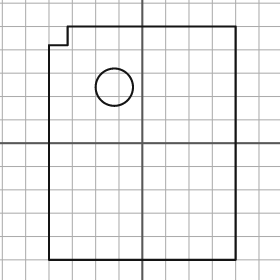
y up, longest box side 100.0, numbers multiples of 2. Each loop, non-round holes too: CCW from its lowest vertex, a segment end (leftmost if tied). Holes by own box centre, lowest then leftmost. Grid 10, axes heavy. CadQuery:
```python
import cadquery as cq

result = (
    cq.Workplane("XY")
    .moveTo(-40.0, -50.0)
    .lineTo(40.0, -50.0)
    .lineTo(40.0, 50.0)
    .lineTo(-32.0, 50.0)
    .lineTo(-32.0, 42.0)
    .lineTo(-40.0, 42.0)
    .close()
    .moveTo(-12.0, 24.0)
    .circle(8.0)
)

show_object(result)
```